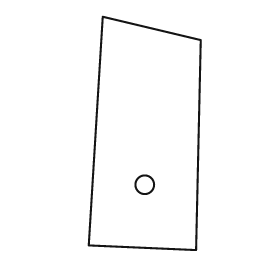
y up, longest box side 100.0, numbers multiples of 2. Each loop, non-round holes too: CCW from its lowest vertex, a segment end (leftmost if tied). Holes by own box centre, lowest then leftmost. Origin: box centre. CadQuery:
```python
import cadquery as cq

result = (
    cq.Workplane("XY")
    .moveTo(22.0, -50.0)
    .lineTo(24.0, 40.0)
    .lineTo(-18.0, 50.0)
    .lineTo(-24.0, -48.0)
    .close()
    .moveTo(0.0, -22.0)
    .circle(4.0)
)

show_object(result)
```